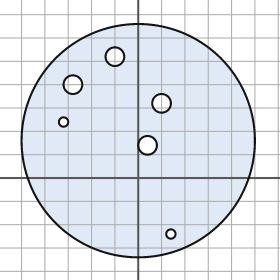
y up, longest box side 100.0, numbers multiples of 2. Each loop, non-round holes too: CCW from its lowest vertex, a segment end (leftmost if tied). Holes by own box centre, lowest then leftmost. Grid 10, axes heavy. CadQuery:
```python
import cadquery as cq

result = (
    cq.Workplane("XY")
    .moveTo(0.0, 16.0)
    .circle(50.0)
    .moveTo(14.0, -24.0)
    .circle(2.0)
    .moveTo(4.0, 14.0)
    .circle(4.0)
    .moveTo(-32.0, 24.0)
    .circle(2.0)
    .moveTo(10.0, 32.0)
    .circle(4.0)
    .moveTo(-28.0, 40.0)
    .circle(4.0)
    .moveTo(-10.0, 52.0)
    .circle(4.0)
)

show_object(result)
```